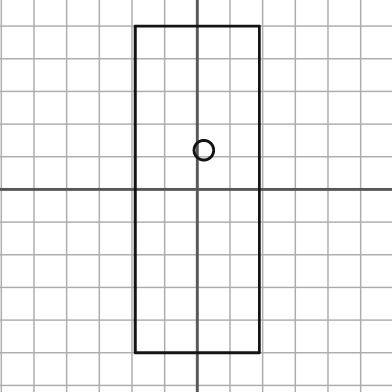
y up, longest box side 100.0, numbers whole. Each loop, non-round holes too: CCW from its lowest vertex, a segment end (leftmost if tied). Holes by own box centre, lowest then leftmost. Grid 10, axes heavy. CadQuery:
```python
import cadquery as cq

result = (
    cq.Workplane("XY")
    .moveTo(-19.0, -50.0)
    .lineTo(19.0, -50.0)
    .lineTo(19.0, 50.0)
    .lineTo(-19.0, 50.0)
    .close()
    .moveTo(2.0, 12.0)
    .circle(3.0)
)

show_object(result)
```